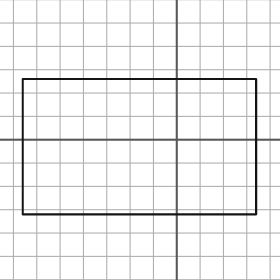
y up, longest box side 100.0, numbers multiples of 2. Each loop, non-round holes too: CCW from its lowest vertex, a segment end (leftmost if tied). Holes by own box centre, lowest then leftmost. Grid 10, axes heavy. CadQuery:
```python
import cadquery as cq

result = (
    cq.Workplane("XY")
    .moveTo(-66.0, -32.0)
    .lineTo(34.0, -32.0)
    .lineTo(34.0, 26.0)
    .lineTo(-66.0, 26.0)
    .close()
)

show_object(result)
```